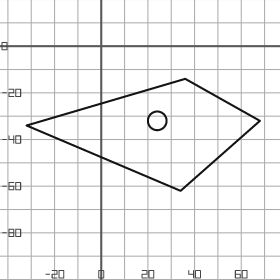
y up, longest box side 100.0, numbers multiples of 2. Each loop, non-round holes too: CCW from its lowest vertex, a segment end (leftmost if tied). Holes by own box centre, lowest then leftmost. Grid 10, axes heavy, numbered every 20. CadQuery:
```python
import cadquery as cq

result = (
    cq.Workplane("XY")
    .moveTo(34.0, -62.0)
    .lineTo(68.0, -32.0)
    .lineTo(36.0, -14.0)
    .lineTo(-32.0, -34.0)
    .close()
    .moveTo(24.0, -32.0)
    .circle(4.0)
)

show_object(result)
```